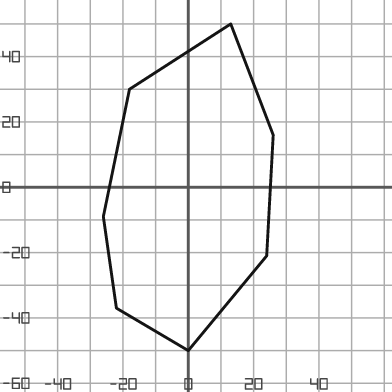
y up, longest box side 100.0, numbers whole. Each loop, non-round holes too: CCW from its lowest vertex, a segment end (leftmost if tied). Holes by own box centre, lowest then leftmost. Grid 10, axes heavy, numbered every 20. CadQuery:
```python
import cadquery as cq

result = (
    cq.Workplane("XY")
    .moveTo(0.0, -50.0)
    .lineTo(24.0, -21.0)
    .lineTo(26.0, 16.0)
    .lineTo(13.0, 50.0)
    .lineTo(-18.0, 30.0)
    .lineTo(-26.0, -9.0)
    .lineTo(-22.0, -37.0)
    .close()
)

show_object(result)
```